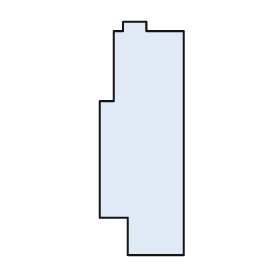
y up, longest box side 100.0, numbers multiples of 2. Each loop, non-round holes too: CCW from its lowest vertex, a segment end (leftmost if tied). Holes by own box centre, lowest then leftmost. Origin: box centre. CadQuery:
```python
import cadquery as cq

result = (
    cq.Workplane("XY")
    .moveTo(-6.0, -50.0)
    .lineTo(18.0, -50.0)
    .lineTo(18.0, 46.0)
    .lineTo(2.0, 46.0)
    .lineTo(2.0, 50.0)
    .lineTo(-8.0, 50.0)
    .lineTo(-8.0, 46.0)
    .lineTo(-12.0, 46.0)
    .lineTo(-12.0, 16.0)
    .lineTo(-18.0, 16.0)
    .lineTo(-18.0, -34.0)
    .lineTo(-6.0, -34.0)
    .close()
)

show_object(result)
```